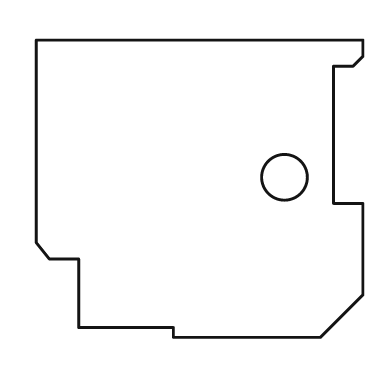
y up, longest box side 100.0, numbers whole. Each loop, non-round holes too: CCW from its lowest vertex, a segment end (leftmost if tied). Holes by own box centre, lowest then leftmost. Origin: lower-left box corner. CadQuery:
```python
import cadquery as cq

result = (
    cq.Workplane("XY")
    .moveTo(42.0, 0.0)
    .lineTo(87.0, 0.0)
    .lineTo(100.0, 13.0)
    .lineTo(100.0, 41.0)
    .lineTo(91.0, 41.0)
    .lineTo(91.0, 83.0)
    .lineTo(97.0, 83.0)
    .lineTo(100.0, 86.0)
    .lineTo(100.0, 91.0)
    .lineTo(0.0, 91.0)
    .lineTo(0.0, 29.0)
    .lineTo(4.0, 24.0)
    .lineTo(13.0, 24.0)
    .lineTo(13.0, 3.0)
    .lineTo(42.0, 3.0)
    .close()
    .moveTo(76.0, 49.0)
    .circle(7.0)
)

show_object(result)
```